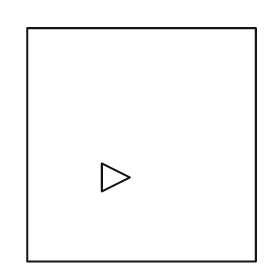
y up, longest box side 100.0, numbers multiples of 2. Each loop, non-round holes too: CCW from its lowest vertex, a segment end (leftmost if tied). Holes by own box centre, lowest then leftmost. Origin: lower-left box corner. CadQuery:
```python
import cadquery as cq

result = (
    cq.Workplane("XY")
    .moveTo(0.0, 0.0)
    .lineTo(98.0, 0.0)
    .lineTo(98.0, 100.0)
    .lineTo(0.0, 100.0)
    .close()
    .moveTo(32.0, 30.0)
    .lineTo(44.0, 36.0)
    .lineTo(32.0, 42.0)
    .close()
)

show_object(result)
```